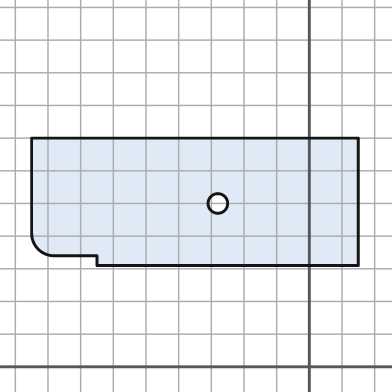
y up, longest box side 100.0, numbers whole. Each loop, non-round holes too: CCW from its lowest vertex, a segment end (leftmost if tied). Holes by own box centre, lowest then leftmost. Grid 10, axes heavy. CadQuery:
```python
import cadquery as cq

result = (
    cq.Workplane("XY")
    .moveTo(-65.0, 31.0)
    .lineTo(15.0, 31.0)
    .lineTo(15.0, 70.0)
    .lineTo(-85.0, 70.0)
    .lineTo(-85.0, 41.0)
    .threePointArc((-83.0, 36.0), (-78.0, 34.0))
    .lineTo(-65.0, 34.0)
    .close()
    .moveTo(-28.0, 50.0)
    .circle(3.0)
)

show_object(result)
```